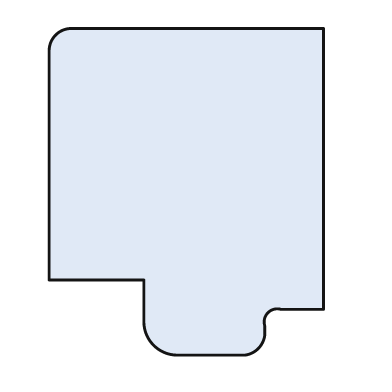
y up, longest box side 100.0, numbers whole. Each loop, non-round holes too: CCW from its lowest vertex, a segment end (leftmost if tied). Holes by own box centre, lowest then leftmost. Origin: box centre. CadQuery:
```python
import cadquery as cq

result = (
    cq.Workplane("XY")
    .moveTo(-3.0, -50.0)
    .lineTo(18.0, -50.0)
    .threePointArc((22.0, -48.0), (24.0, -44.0))
    .lineTo(24.0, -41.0)
    .threePointArc((25.0, -37.0), (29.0, -36.0))
    .lineTo(42.0, -36.0)
    .lineTo(42.0, 50.0)
    .lineTo(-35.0, 50.0)
    .threePointArc((-40.0, 48.0), (-42.0, 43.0))
    .lineTo(-42.0, -27.0)
    .lineTo(-13.0, -27.0)
    .lineTo(-13.0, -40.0)
    .threePointArc((-10.0, -47.0), (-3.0, -50.0))
    .close()
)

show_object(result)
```